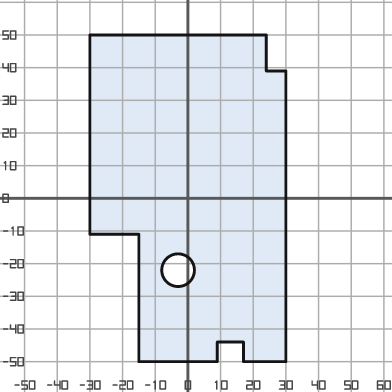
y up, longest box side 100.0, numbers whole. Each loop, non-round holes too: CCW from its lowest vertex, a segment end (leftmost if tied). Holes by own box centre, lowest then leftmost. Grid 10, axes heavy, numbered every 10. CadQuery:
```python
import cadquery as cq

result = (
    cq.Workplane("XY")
    .moveTo(-15.0, -50.0)
    .lineTo(9.0, -50.0)
    .lineTo(9.0, -44.0)
    .lineTo(17.0, -44.0)
    .lineTo(17.0, -50.0)
    .lineTo(30.0, -50.0)
    .lineTo(30.0, 39.0)
    .lineTo(24.0, 39.0)
    .lineTo(24.0, 50.0)
    .lineTo(-30.0, 50.0)
    .lineTo(-30.0, -11.0)
    .lineTo(-15.0, -11.0)
    .close()
    .moveTo(-3.0, -22.0)
    .circle(5.0)
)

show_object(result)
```